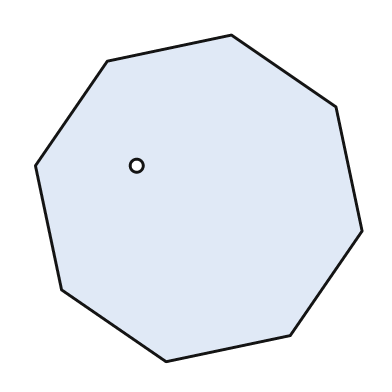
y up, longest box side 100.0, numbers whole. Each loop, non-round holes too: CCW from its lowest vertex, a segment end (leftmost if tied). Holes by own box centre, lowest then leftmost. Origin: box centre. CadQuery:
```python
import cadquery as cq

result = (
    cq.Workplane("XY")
    .moveTo(-10.0, -50.0)
    .lineTo(28.0, -42.0)
    .lineTo(50.0, -10.0)
    .lineTo(42.0, 28.0)
    .lineTo(10.0, 50.0)
    .lineTo(-28.0, 42.0)
    .lineTo(-50.0, 10.0)
    .lineTo(-42.0, -28.0)
    .close()
    .moveTo(-19.0, 10.0)
    .circle(2.0)
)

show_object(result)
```